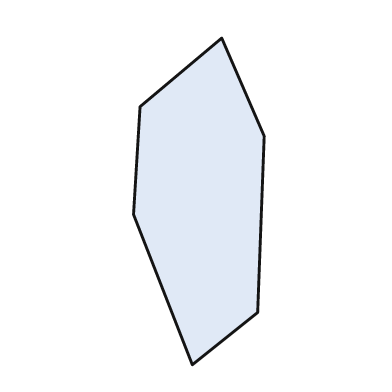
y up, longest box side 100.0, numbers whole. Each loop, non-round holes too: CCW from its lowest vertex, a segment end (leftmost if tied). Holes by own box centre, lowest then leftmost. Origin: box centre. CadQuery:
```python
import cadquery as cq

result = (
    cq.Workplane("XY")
    .moveTo(-2.0, -50.0)
    .lineTo(18.0, -34.0)
    .lineTo(20.0, 20.0)
    .lineTo(7.0, 50.0)
    .lineTo(-18.0, 29.0)
    .lineTo(-20.0, -4.0)
    .close()
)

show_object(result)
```